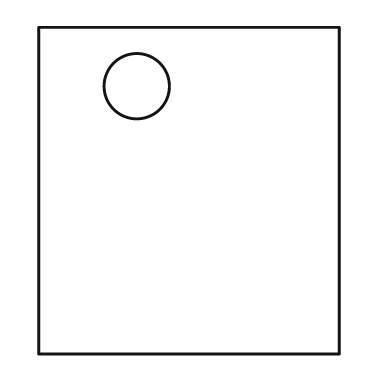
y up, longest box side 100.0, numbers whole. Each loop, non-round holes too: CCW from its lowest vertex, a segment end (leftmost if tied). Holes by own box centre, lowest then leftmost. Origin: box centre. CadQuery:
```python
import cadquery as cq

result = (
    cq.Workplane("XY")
    .moveTo(-46.0, -50.0)
    .lineTo(46.0, -50.0)
    .lineTo(46.0, 50.0)
    .lineTo(-46.0, 50.0)
    .close()
    .moveTo(-16.0, 32.0)
    .circle(10.0)
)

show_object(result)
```